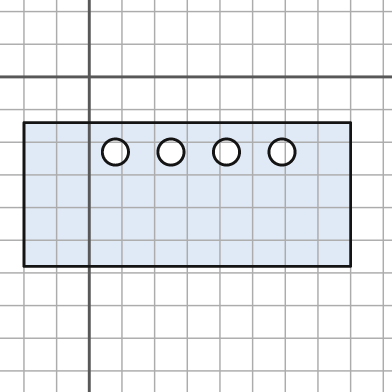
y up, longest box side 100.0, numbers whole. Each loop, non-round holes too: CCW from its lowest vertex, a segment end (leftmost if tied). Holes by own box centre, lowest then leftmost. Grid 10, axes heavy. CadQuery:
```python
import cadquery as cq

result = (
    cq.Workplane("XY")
    .moveTo(-20.0, -58.0)
    .lineTo(80.0, -58.0)
    .lineTo(80.0, -14.0)
    .lineTo(-20.0, -14.0)
    .close()
    .moveTo(8.0, -23.0)
    .circle(4.0)
    .moveTo(25.0, -23.0)
    .circle(4.0)
    .moveTo(42.0, -23.0)
    .circle(4.0)
    .moveTo(59.0, -23.0)
    .circle(4.0)
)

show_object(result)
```